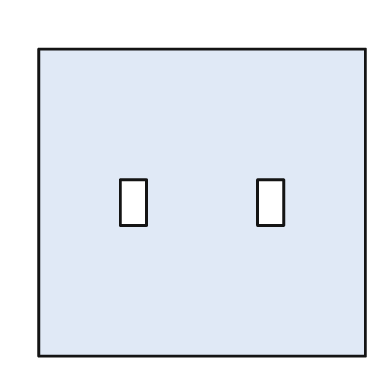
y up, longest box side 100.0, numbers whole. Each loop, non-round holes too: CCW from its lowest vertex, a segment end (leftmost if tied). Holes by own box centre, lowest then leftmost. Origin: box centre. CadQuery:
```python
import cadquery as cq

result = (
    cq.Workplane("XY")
    .moveTo(-50.0, -47.0)
    .lineTo(50.0, -47.0)
    .lineTo(50.0, 47.0)
    .lineTo(-50.0, 47.0)
    .close()
    .moveTo(-25.0, -7.0)
    .lineTo(-17.0, -7.0)
    .lineTo(-17.0, 7.0)
    .lineTo(-25.0, 7.0)
    .close()
    .moveTo(17.0, -7.0)
    .lineTo(25.0, -7.0)
    .lineTo(25.0, 7.0)
    .lineTo(17.0, 7.0)
    .close()
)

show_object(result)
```